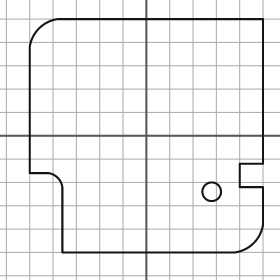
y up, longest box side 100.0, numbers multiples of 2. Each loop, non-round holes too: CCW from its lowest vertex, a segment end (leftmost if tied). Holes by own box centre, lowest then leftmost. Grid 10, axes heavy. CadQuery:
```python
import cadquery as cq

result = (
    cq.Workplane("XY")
    .moveTo(-36.0, -50.0)
    .lineTo(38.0, -50.0)
    .threePointArc((46.0, -46.0), (50.0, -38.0))
    .lineTo(50.0, -22.0)
    .lineTo(40.0, -22.0)
    .lineTo(40.0, -12.0)
    .lineTo(50.0, -12.0)
    .lineTo(50.0, 50.0)
    .lineTo(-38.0, 50.0)
    .threePointArc((-46.0, 46.0), (-50.0, 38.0))
    .lineTo(-50.0, -16.0)
    .lineTo(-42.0, -16.0)
    .threePointArc((-38.0, -18.0), (-36.0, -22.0))
    .close()
    .moveTo(28.0, -24.0)
    .circle(4.0)
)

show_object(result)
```